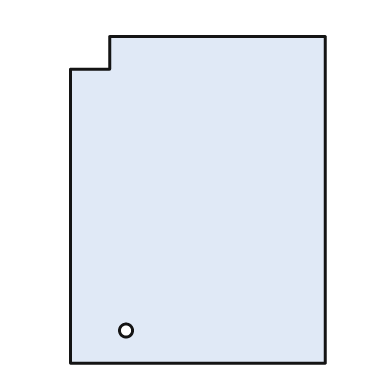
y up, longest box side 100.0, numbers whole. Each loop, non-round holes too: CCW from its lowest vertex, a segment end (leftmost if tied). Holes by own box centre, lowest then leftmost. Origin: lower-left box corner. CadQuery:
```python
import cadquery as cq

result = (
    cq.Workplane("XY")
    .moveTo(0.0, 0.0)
    .lineTo(78.0, 0.0)
    .lineTo(78.0, 100.0)
    .lineTo(12.0, 100.0)
    .lineTo(12.0, 90.0)
    .lineTo(0.0, 90.0)
    .close()
    .moveTo(17.0, 10.0)
    .circle(2.0)
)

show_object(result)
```